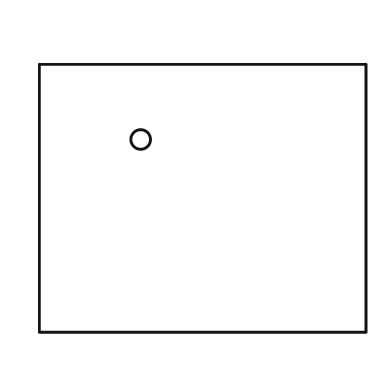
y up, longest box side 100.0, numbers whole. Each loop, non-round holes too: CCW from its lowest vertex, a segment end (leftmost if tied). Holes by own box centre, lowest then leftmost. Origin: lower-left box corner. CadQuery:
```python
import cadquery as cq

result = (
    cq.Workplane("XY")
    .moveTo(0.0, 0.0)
    .lineTo(100.0, 0.0)
    .lineTo(100.0, 82.0)
    .lineTo(0.0, 82.0)
    .close()
    .moveTo(31.0, 59.0)
    .circle(3.0)
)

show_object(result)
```